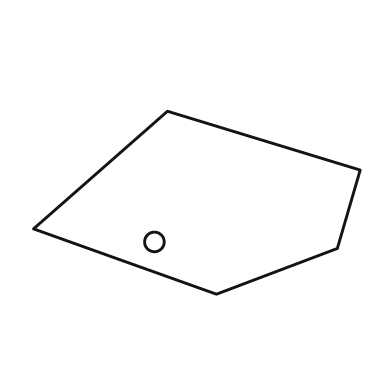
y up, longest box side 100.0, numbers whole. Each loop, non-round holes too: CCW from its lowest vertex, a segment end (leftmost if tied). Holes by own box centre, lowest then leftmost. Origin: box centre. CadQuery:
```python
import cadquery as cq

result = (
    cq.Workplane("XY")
    .moveTo(6.0, -28.0)
    .lineTo(43.0, -14.0)
    .lineTo(50.0, 10.0)
    .lineTo(-9.0, 28.0)
    .lineTo(-50.0, -8.0)
    .close()
    .moveTo(-13.0, -12.0)
    .circle(3.0)
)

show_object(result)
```